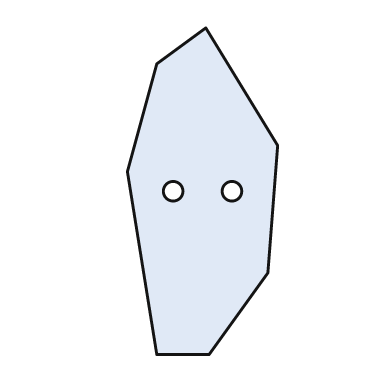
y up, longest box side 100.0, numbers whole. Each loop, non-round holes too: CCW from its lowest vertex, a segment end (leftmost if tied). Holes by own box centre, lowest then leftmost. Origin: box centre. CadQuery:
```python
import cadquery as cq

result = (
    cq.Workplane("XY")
    .moveTo(-14.0, -50.0)
    .lineTo(2.0, -50.0)
    .lineTo(20.0, -25.0)
    .lineTo(23.0, 14.0)
    .lineTo(1.0, 50.0)
    .lineTo(-14.0, 39.0)
    .lineTo(-23.0, 6.0)
    .close()
    .moveTo(-9.0, 0.0)
    .circle(3.0)
    .moveTo(9.0, 0.0)
    .circle(3.0)
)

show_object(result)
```